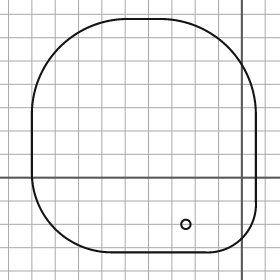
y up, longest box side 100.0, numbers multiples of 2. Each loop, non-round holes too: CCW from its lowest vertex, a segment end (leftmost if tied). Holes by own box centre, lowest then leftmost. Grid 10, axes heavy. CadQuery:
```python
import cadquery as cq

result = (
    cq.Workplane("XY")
    .moveTo(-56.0, -32.0)
    .lineTo(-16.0, -32.0)
    .threePointArc((0.0, -26.0), (6.0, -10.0))
    .lineTo(6.0, 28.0)
    .threePointArc((-6.0, 56.0), (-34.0, 68.0))
    .lineTo(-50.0, 68.0)
    .threePointArc((-78.0, 56.0), (-90.0, 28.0))
    .lineTo(-90.0, 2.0)
    .threePointArc((-80.0, -22.0), (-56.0, -32.0))
    .close()
    .moveTo(-24.0, -20.0)
    .circle(2.0)
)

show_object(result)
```